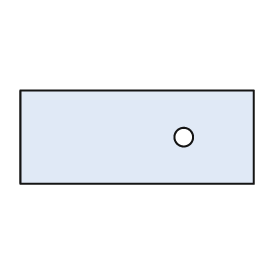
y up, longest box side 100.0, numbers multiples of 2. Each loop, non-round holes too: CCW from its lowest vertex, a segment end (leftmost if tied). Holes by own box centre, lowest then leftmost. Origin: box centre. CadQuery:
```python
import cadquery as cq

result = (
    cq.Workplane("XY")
    .moveTo(-50.0, -20.0)
    .lineTo(50.0, -20.0)
    .lineTo(50.0, 20.0)
    .lineTo(-50.0, 20.0)
    .close()
    .moveTo(20.0, 0.0)
    .circle(4.0)
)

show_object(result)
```